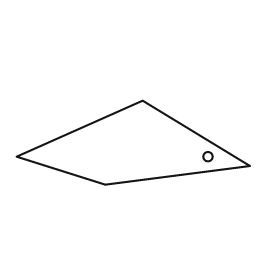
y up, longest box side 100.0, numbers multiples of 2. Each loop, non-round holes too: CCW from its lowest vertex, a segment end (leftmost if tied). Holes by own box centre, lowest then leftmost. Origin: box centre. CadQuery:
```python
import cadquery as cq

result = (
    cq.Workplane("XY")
    .moveTo(-12.0, -18.0)
    .lineTo(50.0, -10.0)
    .lineTo(4.0, 18.0)
    .lineTo(-50.0, -6.0)
    .close()
    .moveTo(32.0, -6.0)
    .circle(2.0)
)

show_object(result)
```